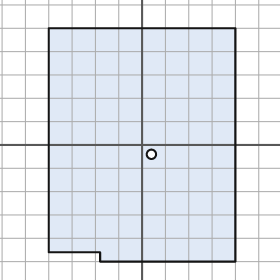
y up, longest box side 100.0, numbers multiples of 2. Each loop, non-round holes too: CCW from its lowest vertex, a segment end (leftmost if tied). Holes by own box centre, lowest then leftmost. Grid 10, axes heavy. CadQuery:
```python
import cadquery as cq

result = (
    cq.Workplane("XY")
    .moveTo(-18.0, -50.0)
    .lineTo(40.0, -50.0)
    .lineTo(40.0, 50.0)
    .lineTo(-40.0, 50.0)
    .lineTo(-40.0, -46.0)
    .lineTo(-18.0, -46.0)
    .close()
    .moveTo(4.0, -4.0)
    .circle(2.0)
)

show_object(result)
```